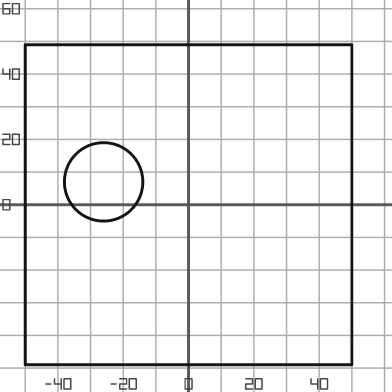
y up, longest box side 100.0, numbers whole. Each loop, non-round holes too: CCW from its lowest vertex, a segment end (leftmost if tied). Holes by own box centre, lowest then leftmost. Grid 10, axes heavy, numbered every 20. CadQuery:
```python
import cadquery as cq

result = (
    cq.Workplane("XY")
    .moveTo(-50.0, -49.0)
    .lineTo(50.0, -49.0)
    .lineTo(50.0, 49.0)
    .lineTo(-50.0, 49.0)
    .close()
    .moveTo(-26.0, 7.0)
    .circle(12.0)
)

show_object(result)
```